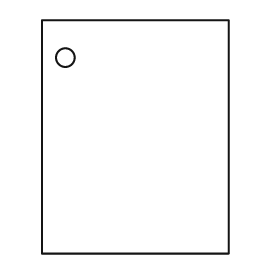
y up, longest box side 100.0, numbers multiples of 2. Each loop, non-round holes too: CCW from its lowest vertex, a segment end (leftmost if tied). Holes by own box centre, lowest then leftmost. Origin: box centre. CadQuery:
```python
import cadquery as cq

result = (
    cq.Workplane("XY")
    .moveTo(-40.0, -50.0)
    .lineTo(40.0, -50.0)
    .lineTo(40.0, 50.0)
    .lineTo(-40.0, 50.0)
    .close()
    .moveTo(-30.0, 34.0)
    .circle(4.0)
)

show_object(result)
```